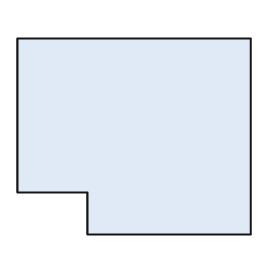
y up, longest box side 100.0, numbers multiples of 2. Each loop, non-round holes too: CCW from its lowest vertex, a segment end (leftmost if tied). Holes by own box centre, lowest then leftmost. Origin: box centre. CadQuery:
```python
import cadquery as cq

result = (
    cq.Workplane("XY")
    .moveTo(-20.0, -42.0)
    .lineTo(50.0, -42.0)
    .lineTo(50.0, 42.0)
    .lineTo(-50.0, 42.0)
    .lineTo(-50.0, -24.0)
    .lineTo(-20.0, -24.0)
    .close()
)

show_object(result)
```